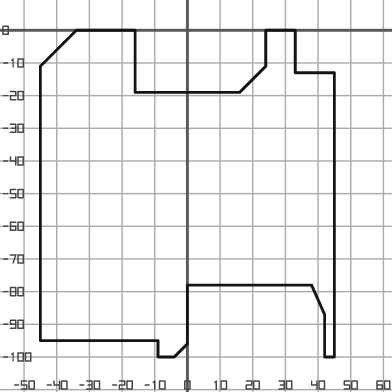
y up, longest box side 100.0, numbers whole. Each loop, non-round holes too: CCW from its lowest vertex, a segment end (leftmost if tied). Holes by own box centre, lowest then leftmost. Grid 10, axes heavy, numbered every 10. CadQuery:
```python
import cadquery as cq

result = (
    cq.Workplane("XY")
    .moveTo(-9.0, -100.0)
    .lineTo(-4.0, -100.0)
    .lineTo(0.0, -96.0)
    .lineTo(0.0, -78.0)
    .lineTo(38.0, -78.0)
    .lineTo(42.0, -87.0)
    .lineTo(42.0, -100.0)
    .lineTo(45.0, -100.0)
    .lineTo(45.0, -13.0)
    .lineTo(33.0, -13.0)
    .lineTo(33.0, 0.0)
    .lineTo(24.0, 0.0)
    .lineTo(24.0, -11.0)
    .lineTo(16.0, -19.0)
    .lineTo(-16.0, -19.0)
    .lineTo(-16.0, 0.0)
    .lineTo(-34.0, 0.0)
    .lineTo(-45.0, -11.0)
    .lineTo(-45.0, -95.0)
    .lineTo(-9.0, -95.0)
    .close()
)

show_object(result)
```